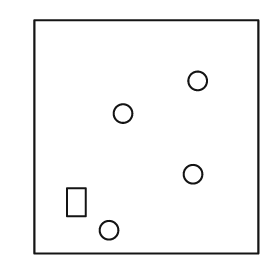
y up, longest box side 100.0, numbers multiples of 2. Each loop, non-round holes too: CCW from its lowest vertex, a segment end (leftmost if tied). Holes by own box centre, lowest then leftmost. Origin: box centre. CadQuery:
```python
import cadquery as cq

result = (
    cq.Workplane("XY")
    .moveTo(-48.0, -50.0)
    .lineTo(48.0, -50.0)
    .lineTo(48.0, 50.0)
    .lineTo(-48.0, 50.0)
    .close()
    .moveTo(-16.0, -40.0)
    .circle(4.0)
    .moveTo(-34.0, -34.0)
    .lineTo(-26.0, -34.0)
    .lineTo(-26.0, -22.0)
    .lineTo(-34.0, -22.0)
    .close()
    .moveTo(20.0, -16.0)
    .circle(4.0)
    .moveTo(-10.0, 10.0)
    .circle(4.0)
    .moveTo(22.0, 24.0)
    .circle(4.0)
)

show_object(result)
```